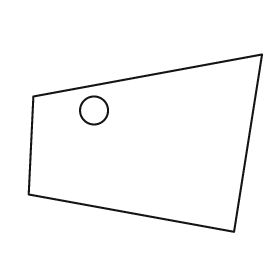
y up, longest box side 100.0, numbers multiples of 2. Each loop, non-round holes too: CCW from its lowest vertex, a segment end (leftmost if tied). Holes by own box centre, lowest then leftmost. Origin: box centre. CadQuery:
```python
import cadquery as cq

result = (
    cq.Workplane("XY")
    .moveTo(38.0, -38.0)
    .lineTo(50.0, 38.0)
    .lineTo(-48.0, 20.0)
    .lineTo(-50.0, -22.0)
    .close()
    .moveTo(-22.0, 14.0)
    .circle(6.0)
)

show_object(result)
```